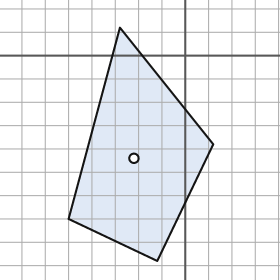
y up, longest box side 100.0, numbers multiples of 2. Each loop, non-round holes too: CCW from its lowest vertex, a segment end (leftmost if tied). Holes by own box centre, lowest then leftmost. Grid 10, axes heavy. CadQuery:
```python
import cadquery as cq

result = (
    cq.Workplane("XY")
    .moveTo(-12.0, -88.0)
    .lineTo(12.0, -38.0)
    .lineTo(-28.0, 12.0)
    .lineTo(-50.0, -70.0)
    .close()
    .moveTo(-22.0, -44.0)
    .circle(2.0)
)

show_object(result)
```